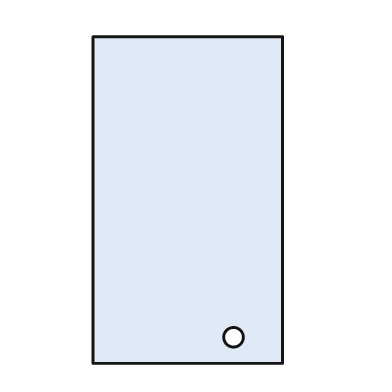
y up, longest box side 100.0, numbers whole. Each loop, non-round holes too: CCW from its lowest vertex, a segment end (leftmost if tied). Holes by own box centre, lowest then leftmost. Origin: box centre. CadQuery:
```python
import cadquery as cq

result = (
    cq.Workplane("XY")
    .moveTo(-29.0, -50.0)
    .lineTo(29.0, -50.0)
    .lineTo(29.0, 50.0)
    .lineTo(-29.0, 50.0)
    .close()
    .moveTo(14.0, -42.0)
    .circle(3.0)
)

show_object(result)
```